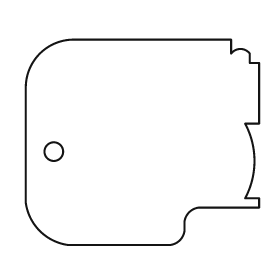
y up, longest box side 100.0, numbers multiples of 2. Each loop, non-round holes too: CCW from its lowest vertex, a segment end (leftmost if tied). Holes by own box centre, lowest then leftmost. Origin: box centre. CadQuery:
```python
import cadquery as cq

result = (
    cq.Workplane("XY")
    .moveTo(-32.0, -44.0)
    .lineTo(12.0, -44.0)
    .threePointArc((16.0, -42.0), (18.0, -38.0))
    .lineTo(18.0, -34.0)
    .threePointArc((20.0, -30.0), (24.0, -28.0))
    .lineTo(50.0, -28.0)
    .lineTo(50.0, -24.0)
    .lineTo(44.0, -24.0)
    .threePointArc((48.0, -8.0), (44.0, 8.0))
    .lineTo(50.0, 8.0)
    .lineTo(50.0, 34.0)
    .lineTo(46.0, 34.0)
    .lineTo(46.0, 38.0)
    .threePointArc((42.0, 40.0), (38.0, 38.0))
    .lineTo(38.0, 44.0)
    .lineTo(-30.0, 44.0)
    .threePointArc((-44.0, 38.0), (-50.0, 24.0))
    .lineTo(-50.0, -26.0)
    .threePointArc((-44.0, -38.0), (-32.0, -44.0))
    .close()
    .moveTo(-38.0, -4.0)
    .circle(4.0)
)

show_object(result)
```